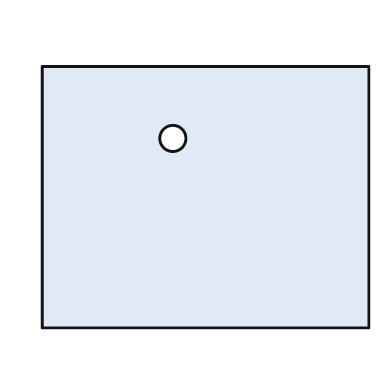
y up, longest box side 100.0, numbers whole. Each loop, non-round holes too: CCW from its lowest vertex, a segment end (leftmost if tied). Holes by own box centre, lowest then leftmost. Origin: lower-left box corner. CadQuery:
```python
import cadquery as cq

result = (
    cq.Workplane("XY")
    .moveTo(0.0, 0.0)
    .lineTo(100.0, 0.0)
    .lineTo(100.0, 80.0)
    .lineTo(0.0, 80.0)
    .close()
    .moveTo(40.0, 58.0)
    .circle(4.0)
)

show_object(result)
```